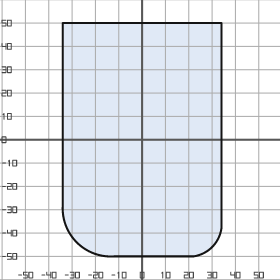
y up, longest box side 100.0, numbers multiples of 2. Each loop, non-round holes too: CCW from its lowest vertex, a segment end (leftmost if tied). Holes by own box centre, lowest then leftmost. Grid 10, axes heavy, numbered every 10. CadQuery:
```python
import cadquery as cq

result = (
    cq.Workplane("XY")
    .moveTo(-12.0, -50.0)
    .lineTo(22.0, -50.0)
    .threePointArc((30.0, -46.0), (34.0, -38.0))
    .lineTo(34.0, 50.0)
    .lineTo(-34.0, 50.0)
    .lineTo(-34.0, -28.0)
    .threePointArc((-28.0, -44.0), (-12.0, -50.0))
    .close()
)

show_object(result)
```